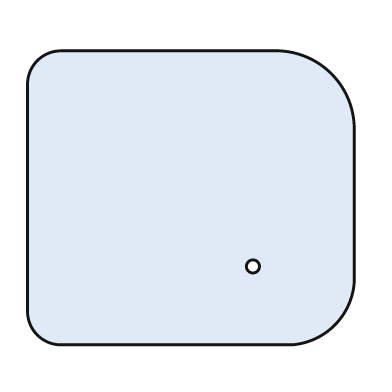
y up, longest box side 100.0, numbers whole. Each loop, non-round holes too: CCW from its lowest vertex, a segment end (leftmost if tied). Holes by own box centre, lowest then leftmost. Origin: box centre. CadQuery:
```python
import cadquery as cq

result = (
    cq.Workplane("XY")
    .moveTo(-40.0, -45.0)
    .lineTo(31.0, -45.0)
    .threePointArc((44.0, -39.0), (50.0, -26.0))
    .lineTo(50.0, 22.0)
    .threePointArc((43.0, 38.0), (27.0, 45.0))
    .lineTo(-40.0, 45.0)
    .threePointArc((-47.0, 42.0), (-50.0, 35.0))
    .lineTo(-50.0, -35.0)
    .threePointArc((-47.0, -42.0), (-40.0, -45.0))
    .close()
    .moveTo(19.0, -21.0)
    .circle(2.0)
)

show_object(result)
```